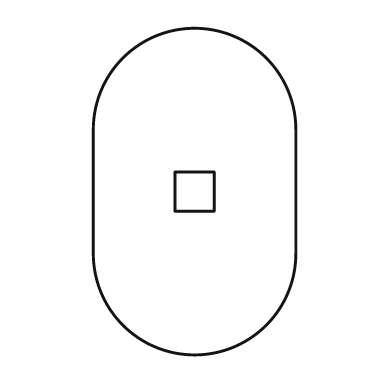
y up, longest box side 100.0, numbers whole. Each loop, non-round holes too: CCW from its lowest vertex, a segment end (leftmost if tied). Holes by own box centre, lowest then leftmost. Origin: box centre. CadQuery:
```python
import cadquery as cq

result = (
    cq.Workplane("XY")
    .moveTo(-31.0, -19.0)
    .threePointArc((0.0, -50.0), (31.0, -19.0))
    .lineTo(31.0, 19.0)
    .threePointArc((0.0, 50.0), (-31.0, 19.0))
    .close()
    .moveTo(-6.0, -6.0)
    .lineTo(6.0, -6.0)
    .lineTo(6.0, 6.0)
    .lineTo(-6.0, 6.0)
    .close()
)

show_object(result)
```